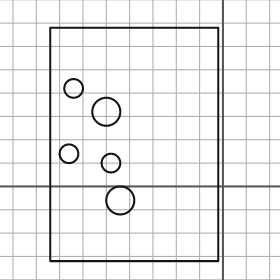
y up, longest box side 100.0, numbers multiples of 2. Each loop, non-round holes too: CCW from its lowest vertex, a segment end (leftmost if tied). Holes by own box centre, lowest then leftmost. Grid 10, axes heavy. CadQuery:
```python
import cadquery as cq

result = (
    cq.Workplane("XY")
    .moveTo(-74.0, -32.0)
    .lineTo(-2.0, -32.0)
    .lineTo(-2.0, 68.0)
    .lineTo(-74.0, 68.0)
    .close()
    .moveTo(-44.0, -6.0)
    .circle(6.0)
    .moveTo(-48.0, 10.0)
    .circle(4.0)
    .moveTo(-66.0, 14.0)
    .circle(4.0)
    .moveTo(-50.0, 32.0)
    .circle(6.0)
    .moveTo(-64.0, 42.0)
    .circle(4.0)
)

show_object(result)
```